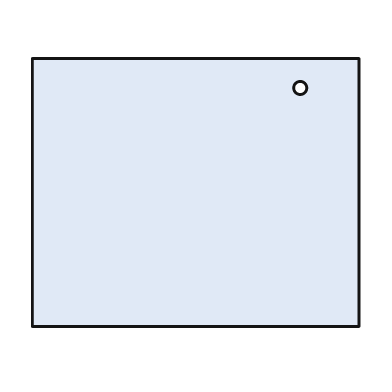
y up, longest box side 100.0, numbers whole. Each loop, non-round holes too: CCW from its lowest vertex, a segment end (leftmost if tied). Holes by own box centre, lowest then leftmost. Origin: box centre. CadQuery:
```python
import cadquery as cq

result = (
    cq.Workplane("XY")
    .moveTo(-50.0, -41.0)
    .lineTo(50.0, -41.0)
    .lineTo(50.0, 41.0)
    .lineTo(-50.0, 41.0)
    .close()
    .moveTo(32.0, 32.0)
    .circle(2.0)
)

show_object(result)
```